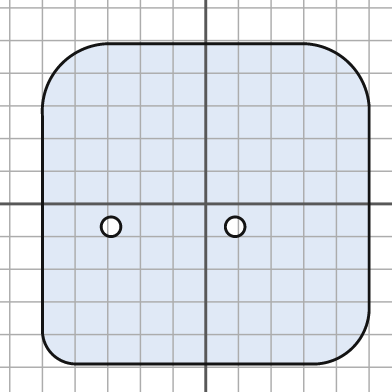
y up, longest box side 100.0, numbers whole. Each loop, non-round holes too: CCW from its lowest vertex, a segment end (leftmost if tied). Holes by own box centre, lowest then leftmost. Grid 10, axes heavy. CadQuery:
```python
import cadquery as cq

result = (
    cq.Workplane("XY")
    .moveTo(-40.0, -49.0)
    .lineTo(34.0, -49.0)
    .threePointArc((45.0, -44.0), (50.0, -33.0))
    .lineTo(50.0, 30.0)
    .threePointArc((44.0, 43.0), (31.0, 49.0))
    .lineTo(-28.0, 49.0)
    .threePointArc((-44.0, 43.0), (-50.0, 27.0))
    .lineTo(-50.0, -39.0)
    .threePointArc((-47.0, -46.0), (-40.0, -49.0))
    .close()
    .moveTo(-29.0, -7.0)
    .circle(3.0)
    .moveTo(9.0, -7.0)
    .circle(3.0)
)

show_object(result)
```